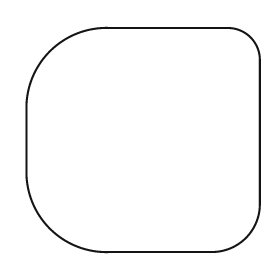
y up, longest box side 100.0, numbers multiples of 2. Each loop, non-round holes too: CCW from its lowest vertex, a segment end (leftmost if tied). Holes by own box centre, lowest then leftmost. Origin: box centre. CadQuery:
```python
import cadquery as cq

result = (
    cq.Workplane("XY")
    .moveTo(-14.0, -48.0)
    .lineTo(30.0, -48.0)
    .threePointArc((44.0, -42.0), (50.0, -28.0))
    .lineTo(50.0, 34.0)
    .threePointArc((46.0, 44.0), (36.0, 48.0))
    .lineTo(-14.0, 48.0)
    .threePointArc((-40.0, 38.0), (-50.0, 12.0))
    .lineTo(-50.0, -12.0)
    .threePointArc((-40.0, -38.0), (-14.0, -48.0))
    .close()
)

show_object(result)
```